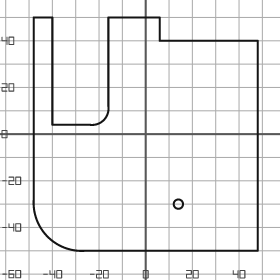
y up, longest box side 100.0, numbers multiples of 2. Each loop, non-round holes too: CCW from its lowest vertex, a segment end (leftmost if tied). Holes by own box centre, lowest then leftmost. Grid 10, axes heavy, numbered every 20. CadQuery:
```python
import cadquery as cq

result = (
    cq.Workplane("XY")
    .moveTo(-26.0, -50.0)
    .lineTo(48.0, -50.0)
    .lineTo(48.0, 40.0)
    .lineTo(6.0, 40.0)
    .lineTo(6.0, 50.0)
    .lineTo(-16.0, 50.0)
    .lineTo(-16.0, 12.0)
    .threePointArc((-18.0, 6.0), (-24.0, 4.0))
    .lineTo(-40.0, 4.0)
    .lineTo(-40.0, 50.0)
    .lineTo(-48.0, 50.0)
    .lineTo(-48.0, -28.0)
    .threePointArc((-42.0, -44.0), (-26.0, -50.0))
    .close()
    .moveTo(14.0, -30.0)
    .circle(2.0)
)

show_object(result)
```